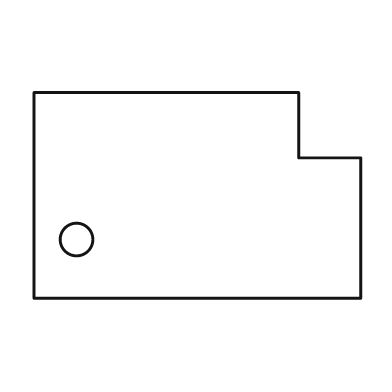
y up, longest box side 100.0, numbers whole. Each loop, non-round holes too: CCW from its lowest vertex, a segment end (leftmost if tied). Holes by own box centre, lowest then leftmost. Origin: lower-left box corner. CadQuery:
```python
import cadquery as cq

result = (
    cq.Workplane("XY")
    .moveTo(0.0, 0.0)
    .lineTo(100.0, 0.0)
    .lineTo(100.0, 43.0)
    .lineTo(81.0, 43.0)
    .lineTo(81.0, 63.0)
    .lineTo(0.0, 63.0)
    .close()
    .moveTo(13.0, 18.0)
    .circle(5.0)
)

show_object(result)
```